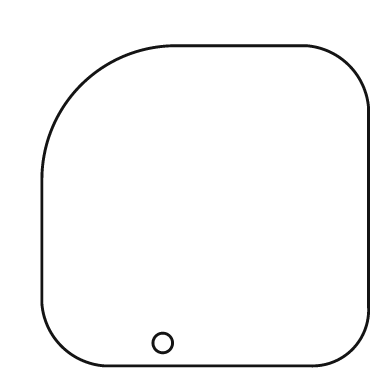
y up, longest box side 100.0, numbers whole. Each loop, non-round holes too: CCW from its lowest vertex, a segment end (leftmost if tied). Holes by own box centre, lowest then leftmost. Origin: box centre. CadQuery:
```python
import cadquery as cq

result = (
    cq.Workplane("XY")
    .moveTo(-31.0, -49.0)
    .lineTo(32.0, -49.0)
    .threePointArc((45.0, -44.0), (50.0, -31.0))
    .lineTo(50.0, 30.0)
    .threePointArc((44.0, 43.0), (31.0, 49.0))
    .lineTo(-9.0, 49.0)
    .threePointArc((-38.0, 37.0), (-50.0, 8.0))
    .lineTo(-50.0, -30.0)
    .threePointArc((-44.0, -43.0), (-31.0, -49.0))
    .close()
    .moveTo(-13.0, -42.0)
    .circle(3.0)
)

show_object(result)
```